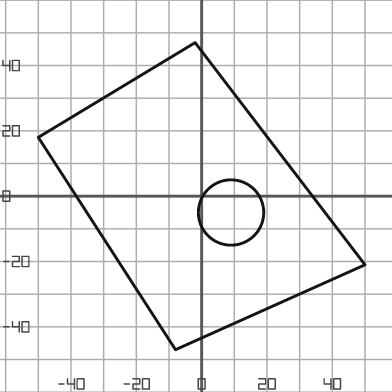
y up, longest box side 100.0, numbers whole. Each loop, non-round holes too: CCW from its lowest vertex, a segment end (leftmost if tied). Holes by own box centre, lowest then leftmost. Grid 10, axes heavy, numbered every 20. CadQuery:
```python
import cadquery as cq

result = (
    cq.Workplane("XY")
    .moveTo(-8.0, -47.0)
    .lineTo(50.0, -21.0)
    .lineTo(-2.0, 47.0)
    .lineTo(-50.0, 18.0)
    .close()
    .moveTo(9.0, -5.0)
    .circle(10.0)
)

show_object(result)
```